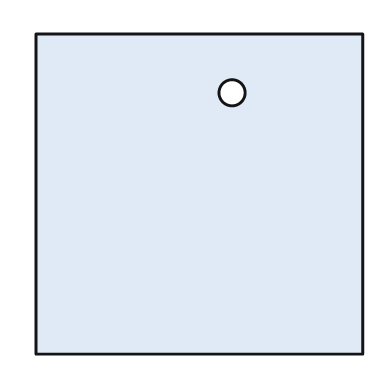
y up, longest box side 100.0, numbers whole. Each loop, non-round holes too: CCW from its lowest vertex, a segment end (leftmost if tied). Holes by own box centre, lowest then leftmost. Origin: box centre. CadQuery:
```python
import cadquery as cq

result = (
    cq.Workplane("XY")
    .moveTo(-50.0, -49.0)
    .lineTo(50.0, -49.0)
    .lineTo(50.0, 49.0)
    .lineTo(-50.0, 49.0)
    .close()
    .moveTo(10.0, 31.0)
    .circle(4.0)
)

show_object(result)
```